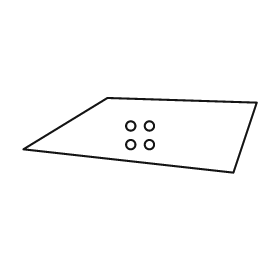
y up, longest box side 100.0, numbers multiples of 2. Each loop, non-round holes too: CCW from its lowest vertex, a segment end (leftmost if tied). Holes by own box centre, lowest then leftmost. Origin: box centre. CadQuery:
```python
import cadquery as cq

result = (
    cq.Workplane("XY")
    .moveTo(40.0, -16.0)
    .lineTo(50.0, 14.0)
    .lineTo(-14.0, 16.0)
    .lineTo(-50.0, -6.0)
    .close()
    .moveTo(-4.0, -4.0)
    .circle(2.0)
    .moveTo(4.0, -4.0)
    .circle(2.0)
    .moveTo(-4.0, 4.0)
    .circle(2.0)
    .moveTo(4.0, 4.0)
    .circle(2.0)
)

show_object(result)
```